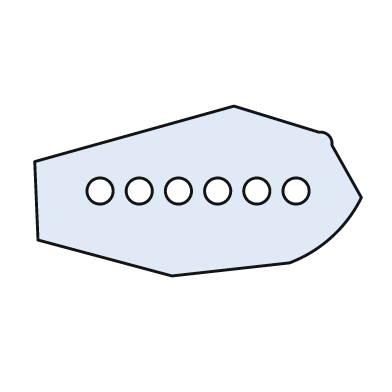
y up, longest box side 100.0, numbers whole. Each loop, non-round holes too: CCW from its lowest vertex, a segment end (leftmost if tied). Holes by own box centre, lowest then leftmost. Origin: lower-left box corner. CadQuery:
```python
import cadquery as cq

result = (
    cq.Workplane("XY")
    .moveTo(42.0, 0.0)
    .lineTo(78.0, 4.0)
    .threePointArc((91.0, 12.0), (100.0, 24.0))
    .lineTo(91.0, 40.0)
    .threePointArc((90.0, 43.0), (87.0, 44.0))
    .lineTo(61.0, 52.0)
    .lineTo(0.0, 35.0)
    .lineTo(1.0, 11.0)
    .close()
    .moveTo(20.0, 26.0)
    .circle(4.0)
    .moveTo(32.0, 26.0)
    .circle(4.0)
    .moveTo(44.0, 26.0)
    .circle(4.0)
    .moveTo(56.0, 26.0)
    .circle(4.0)
    .moveTo(68.0, 26.0)
    .circle(4.0)
    .moveTo(80.0, 26.0)
    .circle(4.0)
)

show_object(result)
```